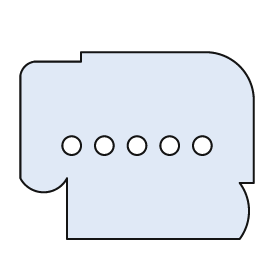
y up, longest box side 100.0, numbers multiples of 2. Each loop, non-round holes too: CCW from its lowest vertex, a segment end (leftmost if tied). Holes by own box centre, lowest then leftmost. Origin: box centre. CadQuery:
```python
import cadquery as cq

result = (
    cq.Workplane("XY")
    .moveTo(-30.0, -40.0)
    .lineTo(44.0, -40.0)
    .threePointArc((48.0, -28.0), (44.0, -16.0))
    .lineTo(50.0, -16.0)
    .lineTo(50.0, 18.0)
    .threePointArc((44.0, 34.0), (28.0, 40.0))
    .lineTo(-24.0, 40.0)
    .lineTo(-24.0, 36.0)
    .lineTo(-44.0, 36.0)
    .threePointArc((-48.0, 34.0), (-50.0, 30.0))
    .lineTo(-50.0, -14.0)
    .threePointArc((-40.0, -20.0), (-30.0, -14.0))
    .close()
    .moveTo(-28.0, 0.0)
    .circle(4.0)
    .moveTo(-14.0, 0.0)
    .circle(4.0)
    .moveTo(0.0, 0.0)
    .circle(4.0)
    .moveTo(14.0, 0.0)
    .circle(4.0)
    .moveTo(28.0, 0.0)
    .circle(4.0)
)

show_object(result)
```